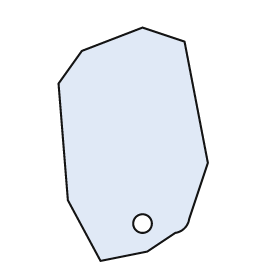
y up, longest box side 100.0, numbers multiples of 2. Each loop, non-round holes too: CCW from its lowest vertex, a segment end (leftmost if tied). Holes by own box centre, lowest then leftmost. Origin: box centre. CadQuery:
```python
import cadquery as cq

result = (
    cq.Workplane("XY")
    .moveTo(-14.0, -50.0)
    .lineTo(6.0, -46.0)
    .lineTo(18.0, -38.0)
    .threePointArc((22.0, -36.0), (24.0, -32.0))
    .lineTo(32.0, -8.0)
    .lineTo(22.0, 44.0)
    .lineTo(4.0, 50.0)
    .lineTo(-22.0, 40.0)
    .lineTo(-32.0, 26.0)
    .lineTo(-28.0, -24.0)
    .close()
    .moveTo(4.0, -34.0)
    .circle(4.0)
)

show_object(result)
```